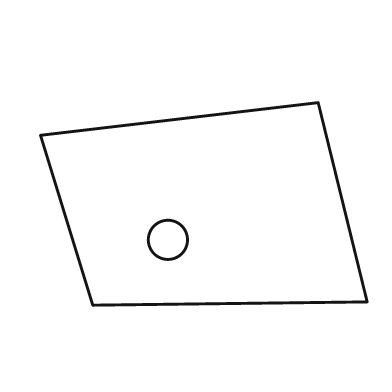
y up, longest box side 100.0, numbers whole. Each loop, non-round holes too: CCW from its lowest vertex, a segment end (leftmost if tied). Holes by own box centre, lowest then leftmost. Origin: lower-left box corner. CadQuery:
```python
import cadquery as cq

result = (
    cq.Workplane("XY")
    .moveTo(16.0, 0.0)
    .lineTo(100.0, 1.0)
    .lineTo(85.0, 62.0)
    .lineTo(0.0, 52.0)
    .close()
    .moveTo(39.0, 20.0)
    .circle(6.0)
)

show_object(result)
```